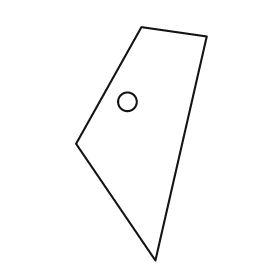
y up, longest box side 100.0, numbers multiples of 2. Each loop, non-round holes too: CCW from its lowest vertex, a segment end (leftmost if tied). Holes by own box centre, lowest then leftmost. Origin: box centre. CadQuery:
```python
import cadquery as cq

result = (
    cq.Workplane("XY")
    .moveTo(6.0, -50.0)
    .lineTo(28.0, 46.0)
    .lineTo(0.0, 50.0)
    .lineTo(-28.0, 0.0)
    .close()
    .moveTo(-6.0, 18.0)
    .circle(4.0)
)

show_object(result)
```